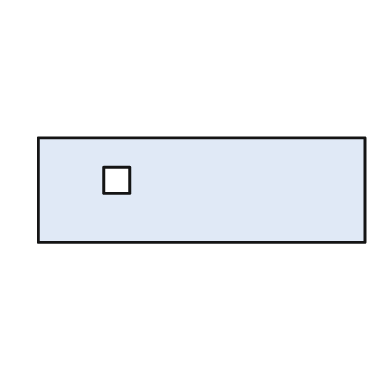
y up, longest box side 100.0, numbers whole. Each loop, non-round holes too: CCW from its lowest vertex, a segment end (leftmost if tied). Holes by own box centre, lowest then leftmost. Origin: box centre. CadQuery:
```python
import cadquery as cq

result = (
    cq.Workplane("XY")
    .moveTo(-50.0, -16.0)
    .lineTo(50.0, -16.0)
    .lineTo(50.0, 16.0)
    .lineTo(-50.0, 16.0)
    .close()
    .moveTo(-30.0, -1.0)
    .lineTo(-22.0, -1.0)
    .lineTo(-22.0, 7.0)
    .lineTo(-30.0, 7.0)
    .close()
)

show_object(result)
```